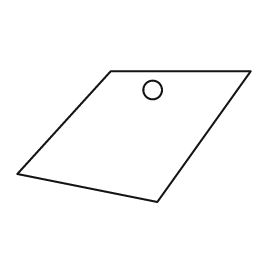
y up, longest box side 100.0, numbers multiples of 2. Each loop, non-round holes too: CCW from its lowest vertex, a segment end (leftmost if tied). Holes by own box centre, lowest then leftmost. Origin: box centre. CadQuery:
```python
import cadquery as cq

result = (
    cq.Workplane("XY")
    .moveTo(10.0, -28.0)
    .lineTo(50.0, 28.0)
    .lineTo(-10.0, 28.0)
    .lineTo(-50.0, -16.0)
    .close()
    .moveTo(8.0, 20.0)
    .circle(4.0)
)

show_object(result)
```